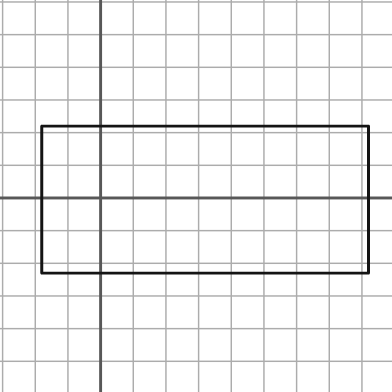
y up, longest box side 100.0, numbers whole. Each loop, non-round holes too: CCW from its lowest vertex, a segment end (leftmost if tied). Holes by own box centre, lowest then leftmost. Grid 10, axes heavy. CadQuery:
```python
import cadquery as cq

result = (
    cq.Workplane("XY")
    .moveTo(-18.0, -23.0)
    .lineTo(82.0, -23.0)
    .lineTo(82.0, 22.0)
    .lineTo(-18.0, 22.0)
    .close()
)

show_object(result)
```